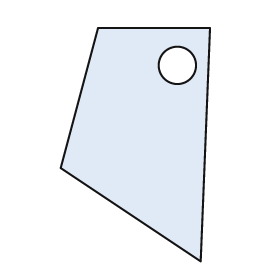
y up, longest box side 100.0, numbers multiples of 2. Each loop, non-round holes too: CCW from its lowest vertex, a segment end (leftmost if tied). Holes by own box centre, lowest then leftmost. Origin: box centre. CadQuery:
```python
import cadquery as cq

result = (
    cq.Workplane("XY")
    .moveTo(28.0, -50.0)
    .lineTo(32.0, 50.0)
    .lineTo(-16.0, 50.0)
    .lineTo(-32.0, -10.0)
    .close()
    .moveTo(18.0, 34.0)
    .circle(8.0)
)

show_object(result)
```